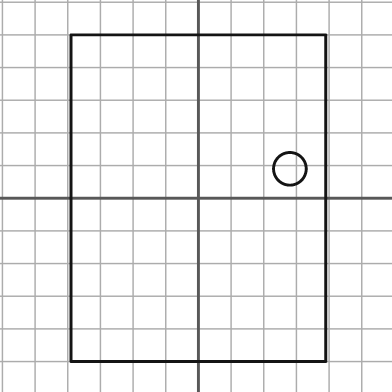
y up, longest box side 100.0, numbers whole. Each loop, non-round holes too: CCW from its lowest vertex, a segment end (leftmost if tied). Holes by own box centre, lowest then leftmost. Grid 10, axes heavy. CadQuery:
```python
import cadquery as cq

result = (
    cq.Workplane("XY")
    .moveTo(-39.0, -50.0)
    .lineTo(39.0, -50.0)
    .lineTo(39.0, 50.0)
    .lineTo(-39.0, 50.0)
    .close()
    .moveTo(28.0, 9.0)
    .circle(5.0)
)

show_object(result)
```